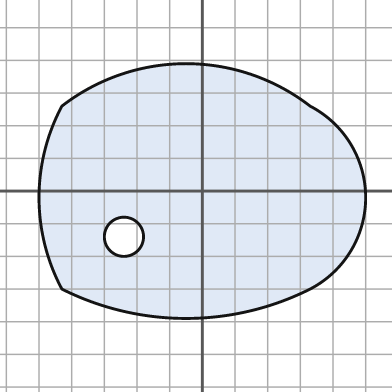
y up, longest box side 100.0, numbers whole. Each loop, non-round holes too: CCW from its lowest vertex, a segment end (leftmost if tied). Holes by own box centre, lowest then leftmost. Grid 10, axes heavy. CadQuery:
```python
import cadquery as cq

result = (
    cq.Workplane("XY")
    .moveTo(-43.0, -30.0)
    .threePointArc((-5.0, -39.0), (33.0, -30.0))
    .threePointArc((50.0, -2.0), (33.0, 26.0))
    .threePointArc((-5.0, 39.0), (-43.0, 26.0))
    .threePointArc((-50.0, -2.0), (-43.0, -30.0))
    .close()
    .moveTo(-24.0, -14.0)
    .circle(6.0)
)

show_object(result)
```